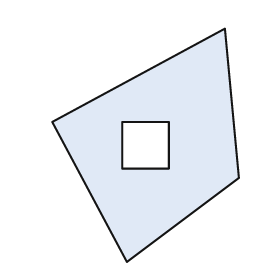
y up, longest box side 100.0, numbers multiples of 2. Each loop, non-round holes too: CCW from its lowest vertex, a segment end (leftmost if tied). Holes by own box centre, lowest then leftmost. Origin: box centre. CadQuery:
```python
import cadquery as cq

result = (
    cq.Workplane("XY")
    .moveTo(-8.0, -50.0)
    .lineTo(40.0, -14.0)
    .lineTo(34.0, 50.0)
    .lineTo(-40.0, 10.0)
    .close()
    .moveTo(-10.0, -10.0)
    .lineTo(10.0, -10.0)
    .lineTo(10.0, 10.0)
    .lineTo(-10.0, 10.0)
    .close()
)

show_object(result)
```